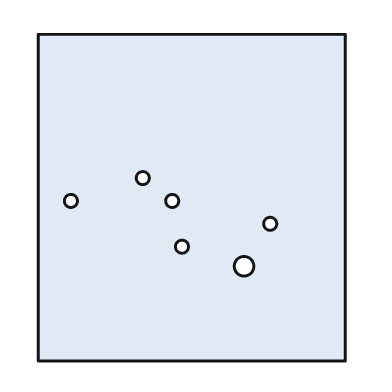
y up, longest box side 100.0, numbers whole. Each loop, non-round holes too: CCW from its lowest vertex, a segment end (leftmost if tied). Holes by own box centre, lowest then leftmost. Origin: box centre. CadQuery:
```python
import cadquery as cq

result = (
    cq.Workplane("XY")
    .moveTo(-47.0, -50.0)
    .lineTo(47.0, -50.0)
    .lineTo(47.0, 50.0)
    .lineTo(-47.0, 50.0)
    .close()
    .moveTo(16.0, -21.0)
    .circle(3.0)
    .moveTo(-3.0, -15.0)
    .circle(2.0)
    .moveTo(24.0, -8.0)
    .circle(2.0)
    .moveTo(-37.0, -1.0)
    .circle(2.0)
    .moveTo(-6.0, -1.0)
    .circle(2.0)
    .moveTo(-15.0, 6.0)
    .circle(2.0)
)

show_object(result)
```